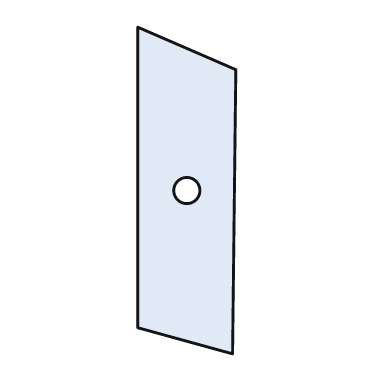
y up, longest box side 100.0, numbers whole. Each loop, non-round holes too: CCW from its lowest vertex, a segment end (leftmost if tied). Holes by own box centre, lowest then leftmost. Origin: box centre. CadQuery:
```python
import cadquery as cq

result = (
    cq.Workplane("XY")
    .moveTo(14.0, -50.0)
    .lineTo(15.0, 37.0)
    .lineTo(-15.0, 50.0)
    .lineTo(-15.0, -42.0)
    .close()
    .moveTo(0.0, 0.0)
    .circle(4.0)
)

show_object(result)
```